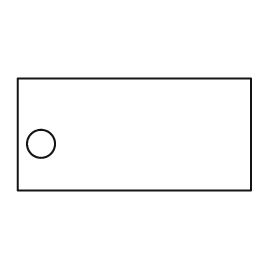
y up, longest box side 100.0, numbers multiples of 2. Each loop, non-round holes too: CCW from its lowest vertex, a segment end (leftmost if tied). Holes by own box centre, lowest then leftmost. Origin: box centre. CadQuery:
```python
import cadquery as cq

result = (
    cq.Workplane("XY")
    .moveTo(-50.0, -24.0)
    .lineTo(50.0, -24.0)
    .lineTo(50.0, 24.0)
    .lineTo(-50.0, 24.0)
    .close()
    .moveTo(-40.0, -4.0)
    .circle(6.0)
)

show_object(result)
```